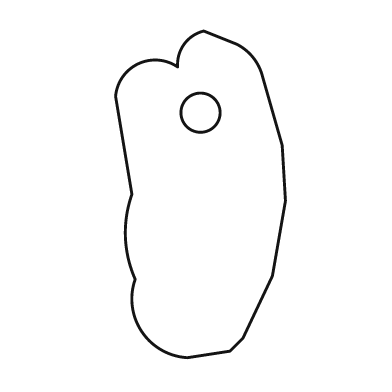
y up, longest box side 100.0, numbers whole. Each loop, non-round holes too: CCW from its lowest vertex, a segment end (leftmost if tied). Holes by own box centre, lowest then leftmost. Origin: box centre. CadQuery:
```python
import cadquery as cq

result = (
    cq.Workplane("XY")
    .moveTo(-4.0, -50.0)
    .lineTo(9.0, -48.0)
    .lineTo(13.0, -44.0)
    .lineTo(22.0, -25.0)
    .lineTo(26.0, -2.0)
    .lineTo(25.0, 15.0)
    .lineTo(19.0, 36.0)
    .threePointArc((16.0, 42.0), (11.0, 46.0))
    .lineTo(1.0, 50.0)
    .threePointArc((-5.0, 46.0), (-7.0, 39.0))
    .threePointArc((-19.0, 40.0), (-26.0, 30.0))
    .lineTo(-21.0, 0.0)
    .threePointArc((-23.0, -13.0), (-20.0, -26.0))
    .threePointArc((-18.0, -42.0), (-4.0, -50.0))
    .close()
    .moveTo(0.0, 25.0)
    .circle(6.0)
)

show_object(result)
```